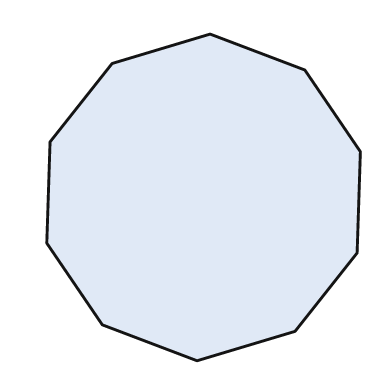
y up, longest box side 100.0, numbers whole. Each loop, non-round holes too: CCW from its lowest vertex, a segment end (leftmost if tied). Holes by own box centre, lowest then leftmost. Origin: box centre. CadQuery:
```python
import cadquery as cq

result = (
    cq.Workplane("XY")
    .moveTo(-2.0, -50.0)
    .lineTo(28.0, -41.0)
    .lineTo(47.0, -17.0)
    .lineTo(48.0, 14.0)
    .lineTo(31.0, 39.0)
    .lineTo(2.0, 50.0)
    .lineTo(-28.0, 41.0)
    .lineTo(-47.0, 17.0)
    .lineTo(-48.0, -14.0)
    .lineTo(-31.0, -39.0)
    .close()
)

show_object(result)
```